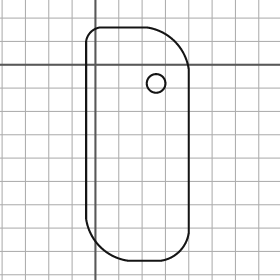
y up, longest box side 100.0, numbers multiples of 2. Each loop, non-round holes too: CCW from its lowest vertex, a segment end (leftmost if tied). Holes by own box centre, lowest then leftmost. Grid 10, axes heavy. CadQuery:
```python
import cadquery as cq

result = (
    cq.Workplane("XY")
    .moveTo(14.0, -84.0)
    .lineTo(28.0, -84.0)
    .threePointArc((36.0, -80.0), (40.0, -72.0))
    .lineTo(40.0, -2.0)
    .threePointArc((34.0, 10.0), (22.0, 16.0))
    .lineTo(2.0, 16.0)
    .threePointArc((-2.0, 14.0), (-4.0, 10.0))
    .lineTo(-4.0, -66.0)
    .threePointArc((2.0, -78.0), (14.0, -84.0))
    .close()
    .moveTo(26.0, -8.0)
    .circle(4.0)
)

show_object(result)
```